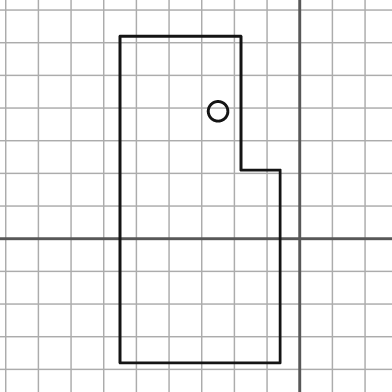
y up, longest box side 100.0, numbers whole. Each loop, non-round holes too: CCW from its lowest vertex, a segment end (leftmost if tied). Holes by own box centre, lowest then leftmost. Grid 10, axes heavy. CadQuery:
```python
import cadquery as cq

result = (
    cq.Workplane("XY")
    .moveTo(-55.0, -38.0)
    .lineTo(-6.0, -38.0)
    .lineTo(-6.0, 21.0)
    .lineTo(-18.0, 21.0)
    .lineTo(-18.0, 62.0)
    .lineTo(-55.0, 62.0)
    .close()
    .moveTo(-25.0, 39.0)
    .circle(3.0)
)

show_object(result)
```